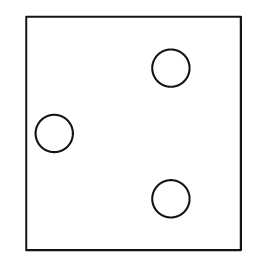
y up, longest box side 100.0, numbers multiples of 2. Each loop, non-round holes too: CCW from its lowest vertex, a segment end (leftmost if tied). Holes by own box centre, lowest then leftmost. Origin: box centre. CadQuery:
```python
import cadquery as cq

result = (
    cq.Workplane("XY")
    .moveTo(-46.0, -50.0)
    .lineTo(46.0, -50.0)
    .lineTo(46.0, 50.0)
    .lineTo(-46.0, 50.0)
    .close()
    .moveTo(16.0, -28.0)
    .circle(8.0)
    .moveTo(-34.0, 0.0)
    .circle(8.0)
    .moveTo(16.0, 28.0)
    .circle(8.0)
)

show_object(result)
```